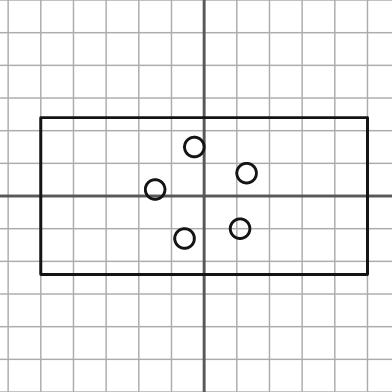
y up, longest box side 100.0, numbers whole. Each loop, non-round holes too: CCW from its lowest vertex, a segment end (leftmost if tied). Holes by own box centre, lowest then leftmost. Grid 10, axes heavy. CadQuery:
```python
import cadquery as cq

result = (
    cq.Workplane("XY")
    .moveTo(-50.0, -24.0)
    .lineTo(50.0, -24.0)
    .lineTo(50.0, 24.0)
    .lineTo(-50.0, 24.0)
    .close()
    .moveTo(-6.0, -13.0)
    .circle(3.0)
    .moveTo(11.0, -10.0)
    .circle(3.0)
    .moveTo(-15.0, 2.0)
    .circle(3.0)
    .moveTo(13.0, 7.0)
    .circle(3.0)
    .moveTo(-3.0, 15.0)
    .circle(3.0)
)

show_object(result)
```